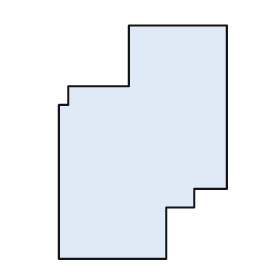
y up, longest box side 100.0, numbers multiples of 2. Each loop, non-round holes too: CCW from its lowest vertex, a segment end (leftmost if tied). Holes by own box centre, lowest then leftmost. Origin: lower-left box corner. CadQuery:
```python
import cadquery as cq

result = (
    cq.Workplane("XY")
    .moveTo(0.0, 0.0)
    .lineTo(46.0, 0.0)
    .lineTo(46.0, 22.0)
    .lineTo(58.0, 22.0)
    .lineTo(58.0, 30.0)
    .lineTo(72.0, 30.0)
    .lineTo(72.0, 100.0)
    .lineTo(30.0, 100.0)
    .lineTo(30.0, 74.0)
    .lineTo(4.0, 74.0)
    .lineTo(4.0, 66.0)
    .lineTo(0.0, 66.0)
    .close()
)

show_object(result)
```